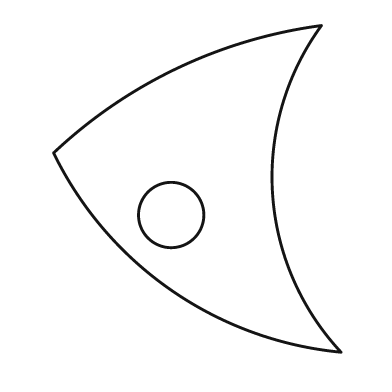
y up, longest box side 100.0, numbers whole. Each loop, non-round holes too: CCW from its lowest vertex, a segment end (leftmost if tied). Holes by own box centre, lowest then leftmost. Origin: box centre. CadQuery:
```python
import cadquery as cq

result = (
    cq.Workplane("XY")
    .moveTo(44.0, -50.0)
    .threePointArc((23.0, -1.0), (38.0, 50.0))
    .threePointArc((-6.0, 37.0), (-44.0, 11.0))
    .threePointArc((-8.0, -31.0), (44.0, -50.0))
    .close()
    .moveTo(-8.0, -8.0)
    .circle(10.0)
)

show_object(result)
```